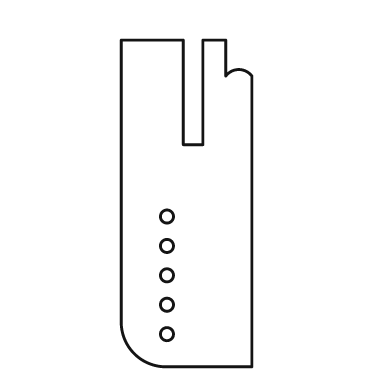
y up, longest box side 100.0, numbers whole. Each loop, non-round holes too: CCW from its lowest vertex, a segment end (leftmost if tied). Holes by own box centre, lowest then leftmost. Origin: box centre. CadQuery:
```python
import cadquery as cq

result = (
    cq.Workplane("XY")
    .moveTo(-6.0, -50.0)
    .lineTo(20.0, -50.0)
    .lineTo(20.0, 39.0)
    .threePointArc((16.0, 41.0), (12.0, 39.0))
    .lineTo(12.0, 50.0)
    .lineTo(5.0, 50.0)
    .lineTo(5.0, 18.0)
    .lineTo(-1.0, 18.0)
    .lineTo(-1.0, 50.0)
    .lineTo(-20.0, 50.0)
    .lineTo(-20.0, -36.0)
    .threePointArc((-16.0, -46.0), (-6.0, -50.0))
    .close()
    .moveTo(-6.0, -40.0)
    .circle(2.0)
    .moveTo(-6.0, -31.0)
    .circle(2.0)
    .moveTo(-6.0, -22.0)
    .circle(2.0)
    .moveTo(-6.0, -13.0)
    .circle(2.0)
    .moveTo(-6.0, -4.0)
    .circle(2.0)
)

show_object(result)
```